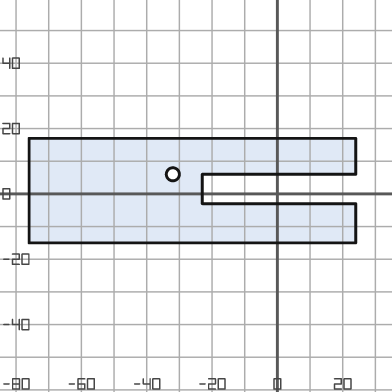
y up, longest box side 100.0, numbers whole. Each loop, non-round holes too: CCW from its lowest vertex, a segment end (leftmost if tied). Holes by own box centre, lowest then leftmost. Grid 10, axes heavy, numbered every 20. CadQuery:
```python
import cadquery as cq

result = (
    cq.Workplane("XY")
    .moveTo(-76.0, -15.0)
    .lineTo(24.0, -15.0)
    .lineTo(24.0, -3.0)
    .lineTo(-23.0, -3.0)
    .lineTo(-23.0, 6.0)
    .lineTo(24.0, 6.0)
    .lineTo(24.0, 17.0)
    .lineTo(-76.0, 17.0)
    .close()
    .moveTo(-32.0, 6.0)
    .circle(2.0)
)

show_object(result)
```